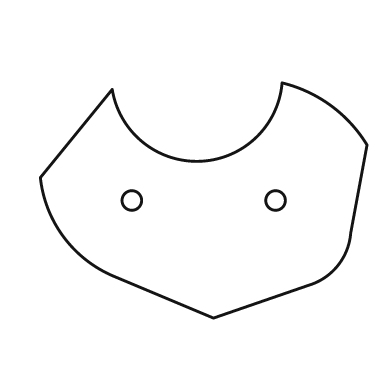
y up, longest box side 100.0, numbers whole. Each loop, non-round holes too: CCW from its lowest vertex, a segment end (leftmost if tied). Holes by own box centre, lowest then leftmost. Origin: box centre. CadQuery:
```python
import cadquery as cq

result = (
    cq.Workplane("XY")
    .moveTo(3.0, -36.0)
    .lineTo(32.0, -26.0)
    .threePointArc((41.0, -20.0), (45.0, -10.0))
    .lineTo(50.0, 17.0)
    .threePointArc((39.0, 29.0), (24.0, 36.0))
    .threePointArc((-1.0, 12.0), (-28.0, 34.0))
    .lineTo(-50.0, 7.0)
    .threePointArc((-43.0, -11.0), (-28.0, -23.0))
    .close()
    .moveTo(-22.0, 0.0)
    .circle(3.0)
    .moveTo(22.0, 0.0)
    .circle(3.0)
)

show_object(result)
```